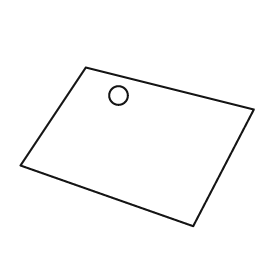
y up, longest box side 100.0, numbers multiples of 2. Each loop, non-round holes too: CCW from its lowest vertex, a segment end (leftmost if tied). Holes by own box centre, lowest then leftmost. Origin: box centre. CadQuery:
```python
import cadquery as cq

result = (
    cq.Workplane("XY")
    .moveTo(24.0, -34.0)
    .lineTo(50.0, 16.0)
    .lineTo(-22.0, 34.0)
    .lineTo(-50.0, -8.0)
    .close()
    .moveTo(-8.0, 22.0)
    .circle(4.0)
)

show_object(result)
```